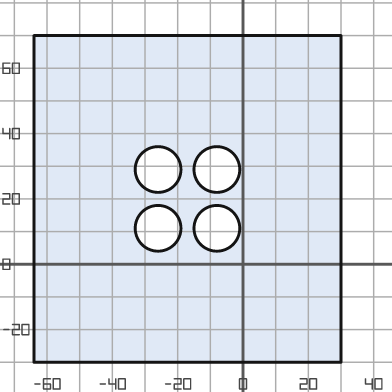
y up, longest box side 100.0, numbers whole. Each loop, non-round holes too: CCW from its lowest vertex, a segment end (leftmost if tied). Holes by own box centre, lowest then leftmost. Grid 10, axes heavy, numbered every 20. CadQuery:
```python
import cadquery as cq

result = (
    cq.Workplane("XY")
    .moveTo(-64.0, -30.0)
    .lineTo(30.0, -30.0)
    .lineTo(30.0, 70.0)
    .lineTo(-64.0, 70.0)
    .close()
    .moveTo(-26.0, 11.0)
    .circle(7.0)
    .moveTo(-8.0, 11.0)
    .circle(7.0)
    .moveTo(-26.0, 29.0)
    .circle(7.0)
    .moveTo(-8.0, 29.0)
    .circle(7.0)
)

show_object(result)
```